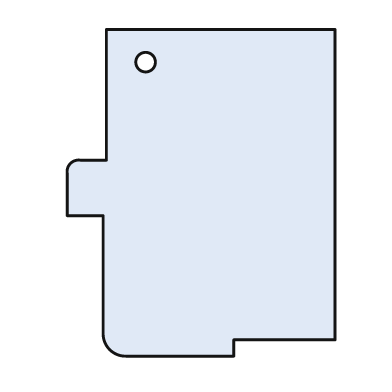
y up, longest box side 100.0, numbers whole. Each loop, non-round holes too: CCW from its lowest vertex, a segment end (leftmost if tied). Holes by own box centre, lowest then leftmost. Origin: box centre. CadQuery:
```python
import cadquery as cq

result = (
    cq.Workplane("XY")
    .moveTo(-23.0, -50.0)
    .lineTo(10.0, -50.0)
    .lineTo(10.0, -45.0)
    .lineTo(41.0, -45.0)
    .lineTo(41.0, 50.0)
    .lineTo(-29.0, 50.0)
    .lineTo(-29.0, 10.0)
    .lineTo(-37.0, 10.0)
    .threePointArc((-40.0, 9.0), (-41.0, 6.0))
    .lineTo(-41.0, -7.0)
    .lineTo(-30.0, -7.0)
    .lineTo(-30.0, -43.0)
    .threePointArc((-28.0, -48.0), (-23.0, -50.0))
    .close()
    .moveTo(-17.0, 40.0)
    .circle(3.0)
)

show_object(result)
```